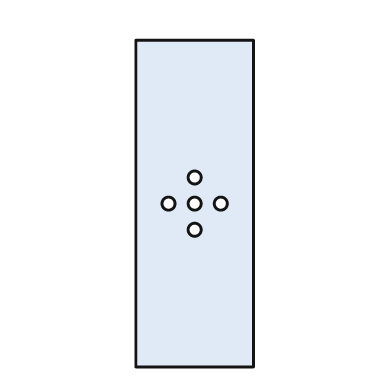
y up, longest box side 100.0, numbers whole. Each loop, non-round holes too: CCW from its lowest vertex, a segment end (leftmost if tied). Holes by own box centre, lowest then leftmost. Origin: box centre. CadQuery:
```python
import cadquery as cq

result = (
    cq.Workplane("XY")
    .moveTo(-18.0, -50.0)
    .lineTo(18.0, -50.0)
    .lineTo(18.0, 50.0)
    .lineTo(-18.0, 50.0)
    .close()
    .moveTo(0.0, -8.0)
    .circle(2.0)
    .moveTo(-8.0, 0.0)
    .circle(2.0)
    .moveTo(0.0, 0.0)
    .circle(2.0)
    .moveTo(8.0, 0.0)
    .circle(2.0)
    .moveTo(0.0, 8.0)
    .circle(2.0)
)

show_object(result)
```